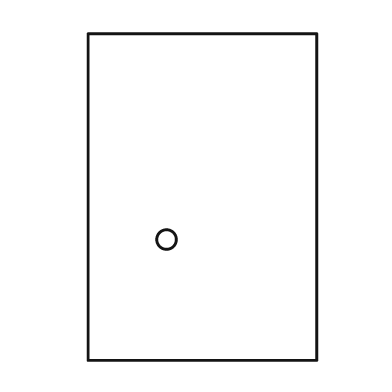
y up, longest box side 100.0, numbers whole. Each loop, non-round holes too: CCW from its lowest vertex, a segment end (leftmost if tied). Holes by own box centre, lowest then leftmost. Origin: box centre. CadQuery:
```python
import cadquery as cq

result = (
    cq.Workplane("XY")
    .moveTo(-35.0, -50.0)
    .lineTo(35.0, -50.0)
    .lineTo(35.0, 50.0)
    .lineTo(-35.0, 50.0)
    .close()
    .moveTo(-11.0, -13.0)
    .circle(3.0)
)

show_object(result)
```